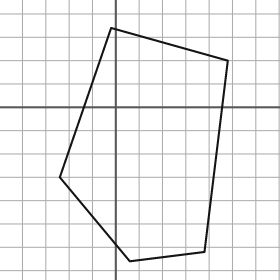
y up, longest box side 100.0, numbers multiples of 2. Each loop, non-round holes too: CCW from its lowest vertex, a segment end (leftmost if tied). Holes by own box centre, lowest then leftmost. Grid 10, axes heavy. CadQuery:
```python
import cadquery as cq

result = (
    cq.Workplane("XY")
    .moveTo(6.0, -66.0)
    .lineTo(38.0, -62.0)
    .lineTo(48.0, 20.0)
    .lineTo(-2.0, 34.0)
    .lineTo(-24.0, -30.0)
    .close()
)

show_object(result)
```